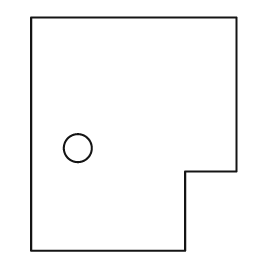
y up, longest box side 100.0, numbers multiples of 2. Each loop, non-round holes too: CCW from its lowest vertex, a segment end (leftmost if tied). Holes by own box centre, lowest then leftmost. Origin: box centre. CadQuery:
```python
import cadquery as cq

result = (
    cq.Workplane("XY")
    .moveTo(-44.0, -50.0)
    .lineTo(22.0, -50.0)
    .lineTo(22.0, -16.0)
    .lineTo(44.0, -16.0)
    .lineTo(44.0, 50.0)
    .lineTo(-44.0, 50.0)
    .close()
    .moveTo(-24.0, -6.0)
    .circle(6.0)
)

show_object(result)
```